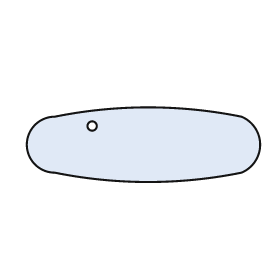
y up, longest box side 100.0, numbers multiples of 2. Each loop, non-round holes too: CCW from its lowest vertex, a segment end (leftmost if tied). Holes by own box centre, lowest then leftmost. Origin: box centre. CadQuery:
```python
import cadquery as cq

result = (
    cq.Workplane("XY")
    .moveTo(-38.0, -12.0)
    .threePointArc((2.0, -16.0), (42.0, -12.0))
    .threePointArc((50.0, 0.0), (42.0, 12.0))
    .threePointArc((2.0, 16.0), (-38.0, 12.0))
    .threePointArc((-50.0, 0.0), (-38.0, -12.0))
    .close()
    .moveTo(-22.0, 8.0)
    .circle(2.0)
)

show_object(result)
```